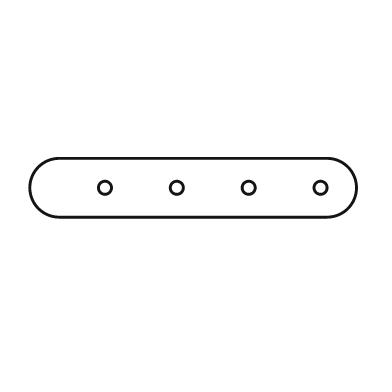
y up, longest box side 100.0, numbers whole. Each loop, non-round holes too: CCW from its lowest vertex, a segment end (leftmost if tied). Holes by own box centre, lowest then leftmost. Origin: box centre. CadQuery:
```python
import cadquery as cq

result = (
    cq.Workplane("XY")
    .moveTo(-41.0, -9.0)
    .lineTo(41.0, -9.0)
    .threePointArc((50.0, 0.0), (41.0, 9.0))
    .lineTo(-41.0, 9.0)
    .threePointArc((-50.0, 0.0), (-41.0, -9.0))
    .close()
    .moveTo(-27.0, 0.0)
    .circle(2.0)
    .moveTo(-5.0, 0.0)
    .circle(2.0)
    .moveTo(17.0, 0.0)
    .circle(2.0)
    .moveTo(39.0, 0.0)
    .circle(2.0)
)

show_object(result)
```